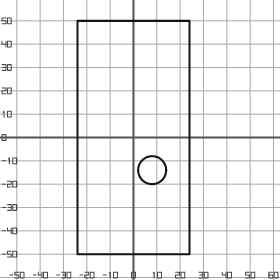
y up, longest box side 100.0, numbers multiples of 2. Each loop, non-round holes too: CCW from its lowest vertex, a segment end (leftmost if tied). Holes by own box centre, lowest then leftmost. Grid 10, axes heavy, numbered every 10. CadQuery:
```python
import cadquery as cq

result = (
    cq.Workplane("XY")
    .moveTo(-24.0, -50.0)
    .lineTo(24.0, -50.0)
    .lineTo(24.0, 50.0)
    .lineTo(-24.0, 50.0)
    .close()
    .moveTo(8.0, -14.0)
    .circle(6.0)
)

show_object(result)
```